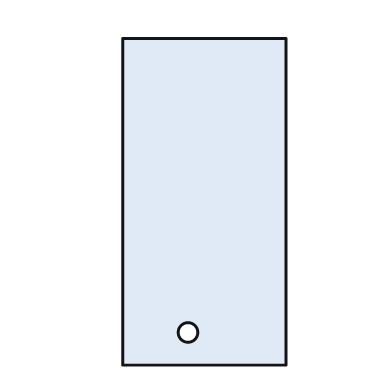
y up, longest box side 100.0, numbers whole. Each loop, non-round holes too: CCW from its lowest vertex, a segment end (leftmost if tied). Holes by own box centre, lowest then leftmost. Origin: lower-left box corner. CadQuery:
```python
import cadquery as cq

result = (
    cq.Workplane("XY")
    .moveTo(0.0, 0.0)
    .lineTo(50.0, 0.0)
    .lineTo(50.0, 100.0)
    .lineTo(0.0, 100.0)
    .close()
    .moveTo(20.0, 10.0)
    .circle(3.0)
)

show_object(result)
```